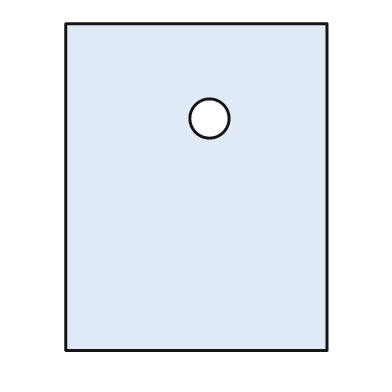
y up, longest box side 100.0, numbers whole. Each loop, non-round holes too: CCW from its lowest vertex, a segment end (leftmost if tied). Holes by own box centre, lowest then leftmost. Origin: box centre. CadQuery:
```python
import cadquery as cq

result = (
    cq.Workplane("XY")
    .moveTo(-40.0, -50.0)
    .lineTo(40.0, -50.0)
    .lineTo(40.0, 50.0)
    .lineTo(-40.0, 50.0)
    .close()
    .moveTo(4.0, 21.0)
    .circle(6.0)
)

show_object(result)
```